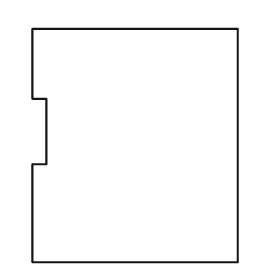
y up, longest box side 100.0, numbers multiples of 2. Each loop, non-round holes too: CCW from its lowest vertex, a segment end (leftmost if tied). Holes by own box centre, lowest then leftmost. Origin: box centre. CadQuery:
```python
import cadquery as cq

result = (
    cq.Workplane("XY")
    .moveTo(-44.0, -50.0)
    .lineTo(44.0, -50.0)
    .lineTo(44.0, 50.0)
    .lineTo(-44.0, 50.0)
    .lineTo(-44.0, 20.0)
    .lineTo(-38.0, 20.0)
    .lineTo(-38.0, -8.0)
    .lineTo(-44.0, -8.0)
    .close()
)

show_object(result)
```